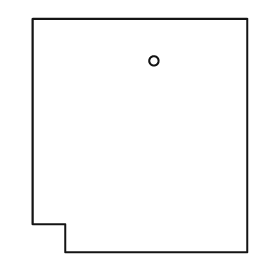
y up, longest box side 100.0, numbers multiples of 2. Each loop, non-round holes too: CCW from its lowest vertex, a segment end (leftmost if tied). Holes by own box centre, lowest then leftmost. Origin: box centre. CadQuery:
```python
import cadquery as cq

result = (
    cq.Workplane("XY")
    .moveTo(-32.0, -50.0)
    .lineTo(46.0, -50.0)
    .lineTo(46.0, 50.0)
    .lineTo(-46.0, 50.0)
    .lineTo(-46.0, -38.0)
    .lineTo(-32.0, -38.0)
    .close()
    .moveTo(6.0, 32.0)
    .circle(2.0)
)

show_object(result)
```